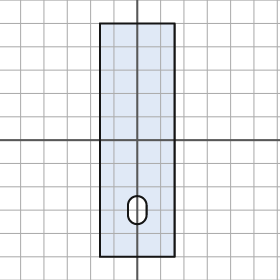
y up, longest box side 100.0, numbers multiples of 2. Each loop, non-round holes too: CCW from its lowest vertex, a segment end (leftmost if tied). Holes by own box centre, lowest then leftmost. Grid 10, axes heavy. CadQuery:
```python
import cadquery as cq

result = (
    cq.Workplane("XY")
    .moveTo(-16.0, -50.0)
    .lineTo(16.0, -50.0)
    .lineTo(16.0, 50.0)
    .lineTo(-16.0, 50.0)
    .close()
    .moveTo(-4.0, -32.0)
    .threePointArc((0.0, -36.0), (4.0, -32.0))
    .lineTo(4.0, -28.0)
    .threePointArc((0.0, -24.0), (-4.0, -28.0))
    .close()
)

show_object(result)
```